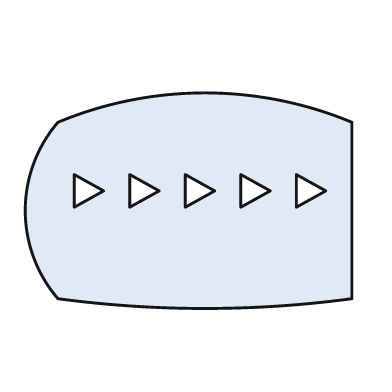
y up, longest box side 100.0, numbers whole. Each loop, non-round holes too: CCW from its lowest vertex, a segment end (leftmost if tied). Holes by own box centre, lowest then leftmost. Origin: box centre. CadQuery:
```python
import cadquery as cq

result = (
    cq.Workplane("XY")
    .moveTo(-40.0, -30.0)
    .threePointArc((5.0, -33.0), (50.0, -30.0))
    .lineTo(50.0, 24.0)
    .threePointArc((5.0, 33.0), (-40.0, 24.0))
    .threePointArc((-50.0, -3.0), (-40.0, -30.0))
    .close()
    .moveTo(-35.0, -2.0)
    .lineTo(-26.0, 3.0)
    .lineTo(-35.0, 8.0)
    .close()
    .moveTo(-18.0, -2.0)
    .lineTo(-9.0, 3.0)
    .lineTo(-18.0, 8.0)
    .close()
    .moveTo(-1.0, -2.0)
    .lineTo(8.0, 3.0)
    .lineTo(-1.0, 8.0)
    .close()
    .moveTo(16.0, -2.0)
    .lineTo(25.0, 3.0)
    .lineTo(16.0, 8.0)
    .close()
    .moveTo(33.0, -2.0)
    .lineTo(42.0, 3.0)
    .lineTo(33.0, 8.0)
    .close()
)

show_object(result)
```